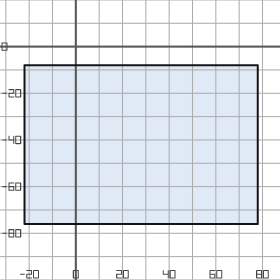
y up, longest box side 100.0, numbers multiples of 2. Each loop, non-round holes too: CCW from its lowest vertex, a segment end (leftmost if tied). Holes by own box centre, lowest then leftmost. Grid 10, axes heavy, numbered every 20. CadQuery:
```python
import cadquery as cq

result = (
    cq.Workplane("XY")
    .moveTo(-22.0, -76.0)
    .lineTo(78.0, -76.0)
    .lineTo(78.0, -8.0)
    .lineTo(-22.0, -8.0)
    .close()
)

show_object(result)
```